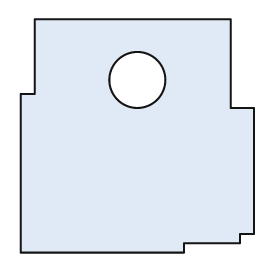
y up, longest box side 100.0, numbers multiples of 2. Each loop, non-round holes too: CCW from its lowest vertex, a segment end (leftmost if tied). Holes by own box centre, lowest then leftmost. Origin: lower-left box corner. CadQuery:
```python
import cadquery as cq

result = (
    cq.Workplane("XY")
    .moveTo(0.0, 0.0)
    .lineTo(70.0, 0.0)
    .lineTo(70.0, 4.0)
    .lineTo(94.0, 4.0)
    .lineTo(94.0, 8.0)
    .lineTo(100.0, 8.0)
    .lineTo(100.0, 62.0)
    .lineTo(90.0, 62.0)
    .lineTo(90.0, 100.0)
    .lineTo(6.0, 100.0)
    .lineTo(6.0, 68.0)
    .lineTo(0.0, 68.0)
    .close()
    .moveTo(50.0, 74.0)
    .circle(12.0)
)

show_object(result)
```